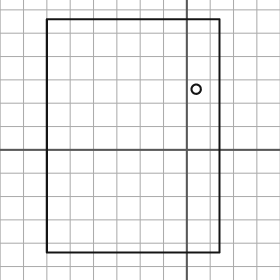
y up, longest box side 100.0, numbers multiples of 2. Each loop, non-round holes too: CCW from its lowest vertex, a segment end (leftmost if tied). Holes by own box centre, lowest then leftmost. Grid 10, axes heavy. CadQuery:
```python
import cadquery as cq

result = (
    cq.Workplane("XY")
    .moveTo(-60.0, -44.0)
    .lineTo(14.0, -44.0)
    .lineTo(14.0, 56.0)
    .lineTo(-60.0, 56.0)
    .close()
    .moveTo(4.0, 26.0)
    .circle(2.0)
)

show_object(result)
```